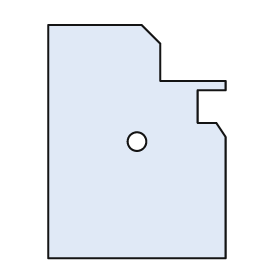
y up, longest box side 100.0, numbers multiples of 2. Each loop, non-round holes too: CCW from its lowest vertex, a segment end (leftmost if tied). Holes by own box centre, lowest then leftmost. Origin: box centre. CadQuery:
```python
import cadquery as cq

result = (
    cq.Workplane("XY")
    .moveTo(-38.0, -50.0)
    .lineTo(38.0, -50.0)
    .lineTo(38.0, 2.0)
    .lineTo(34.0, 8.0)
    .lineTo(26.0, 8.0)
    .lineTo(26.0, 22.0)
    .lineTo(38.0, 22.0)
    .lineTo(38.0, 26.0)
    .lineTo(10.0, 26.0)
    .lineTo(10.0, 42.0)
    .lineTo(2.0, 50.0)
    .lineTo(-38.0, 50.0)
    .close()
    .moveTo(0.0, 0.0)
    .circle(4.0)
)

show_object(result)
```